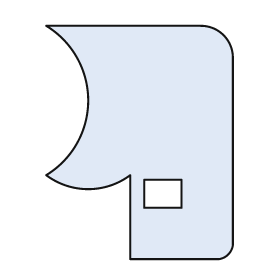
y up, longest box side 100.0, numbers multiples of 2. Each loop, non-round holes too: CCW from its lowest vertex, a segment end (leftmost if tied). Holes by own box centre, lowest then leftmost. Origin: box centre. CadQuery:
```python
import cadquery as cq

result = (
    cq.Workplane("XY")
    .moveTo(-4.0, -50.0)
    .lineTo(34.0, -50.0)
    .threePointArc((38.0, -48.0), (40.0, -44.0))
    .lineTo(40.0, 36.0)
    .threePointArc((36.0, 46.0), (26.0, 50.0))
    .lineTo(-40.0, 50.0)
    .threePointArc((-22.0, 18.0), (-40.0, -14.0))
    .threePointArc((-22.0, -20.0), (-4.0, -14.0))
    .close()
    .moveTo(2.0, -28.0)
    .lineTo(18.0, -28.0)
    .lineTo(18.0, -16.0)
    .lineTo(2.0, -16.0)
    .close()
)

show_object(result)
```